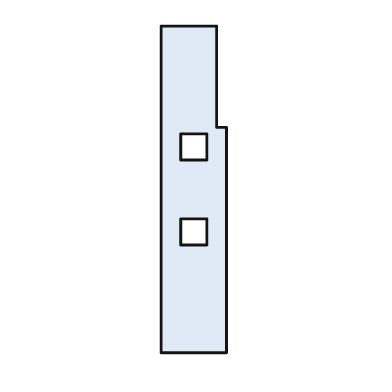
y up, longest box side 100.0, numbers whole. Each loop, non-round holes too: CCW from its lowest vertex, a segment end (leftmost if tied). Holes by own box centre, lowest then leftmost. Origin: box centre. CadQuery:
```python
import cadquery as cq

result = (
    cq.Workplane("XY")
    .moveTo(-10.0, -50.0)
    .lineTo(10.0, -50.0)
    .lineTo(10.0, 19.0)
    .lineTo(7.0, 19.0)
    .lineTo(7.0, 50.0)
    .lineTo(-10.0, 50.0)
    .close()
    .moveTo(-4.0, -17.0)
    .lineTo(4.0, -17.0)
    .lineTo(4.0, -9.0)
    .lineTo(-4.0, -9.0)
    .close()
    .moveTo(-4.0, 9.0)
    .lineTo(4.0, 9.0)
    .lineTo(4.0, 17.0)
    .lineTo(-4.0, 17.0)
    .close()
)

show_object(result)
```